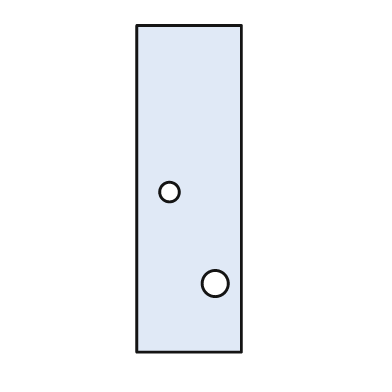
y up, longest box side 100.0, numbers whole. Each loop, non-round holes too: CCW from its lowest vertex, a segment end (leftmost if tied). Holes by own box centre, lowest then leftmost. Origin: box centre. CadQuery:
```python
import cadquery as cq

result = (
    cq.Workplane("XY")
    .moveTo(-16.0, -50.0)
    .lineTo(16.0, -50.0)
    .lineTo(16.0, 50.0)
    .lineTo(-16.0, 50.0)
    .close()
    .moveTo(8.0, -29.0)
    .circle(4.0)
    .moveTo(-6.0, -1.0)
    .circle(3.0)
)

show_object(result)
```